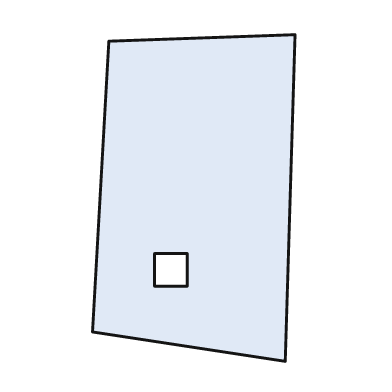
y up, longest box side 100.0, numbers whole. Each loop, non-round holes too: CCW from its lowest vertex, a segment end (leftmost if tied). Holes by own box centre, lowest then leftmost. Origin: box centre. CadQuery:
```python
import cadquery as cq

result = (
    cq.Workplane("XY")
    .moveTo(28.0, -50.0)
    .lineTo(31.0, 50.0)
    .lineTo(-26.0, 48.0)
    .lineTo(-31.0, -41.0)
    .close()
    .moveTo(-12.0, -27.0)
    .lineTo(-2.0, -27.0)
    .lineTo(-2.0, -17.0)
    .lineTo(-12.0, -17.0)
    .close()
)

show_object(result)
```